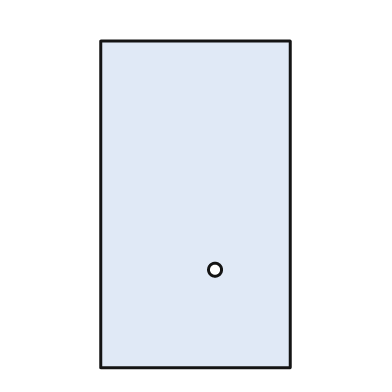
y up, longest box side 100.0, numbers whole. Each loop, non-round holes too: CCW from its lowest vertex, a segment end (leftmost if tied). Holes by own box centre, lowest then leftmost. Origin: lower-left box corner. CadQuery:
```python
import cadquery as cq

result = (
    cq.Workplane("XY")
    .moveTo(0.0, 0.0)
    .lineTo(58.0, 0.0)
    .lineTo(58.0, 100.0)
    .lineTo(0.0, 100.0)
    .close()
    .moveTo(35.0, 30.0)
    .circle(2.0)
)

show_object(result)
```